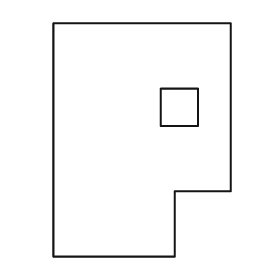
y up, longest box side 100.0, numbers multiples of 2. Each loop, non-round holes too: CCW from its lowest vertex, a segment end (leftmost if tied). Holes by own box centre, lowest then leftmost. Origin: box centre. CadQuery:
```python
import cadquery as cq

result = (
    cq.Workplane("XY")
    .moveTo(-38.0, -50.0)
    .lineTo(14.0, -50.0)
    .lineTo(14.0, -22.0)
    .lineTo(38.0, -22.0)
    .lineTo(38.0, 50.0)
    .lineTo(-38.0, 50.0)
    .close()
    .moveTo(8.0, 6.0)
    .lineTo(24.0, 6.0)
    .lineTo(24.0, 22.0)
    .lineTo(8.0, 22.0)
    .close()
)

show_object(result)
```